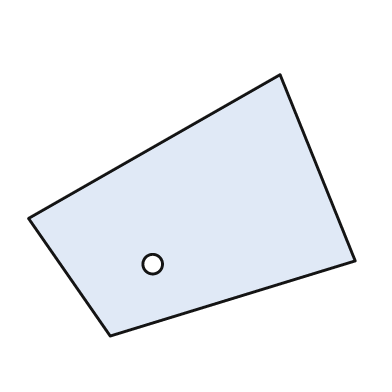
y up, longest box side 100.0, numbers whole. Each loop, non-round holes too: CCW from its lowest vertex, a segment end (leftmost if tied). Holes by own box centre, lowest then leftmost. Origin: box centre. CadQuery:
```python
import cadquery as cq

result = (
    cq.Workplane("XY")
    .moveTo(-25.0, -40.0)
    .lineTo(50.0, -17.0)
    .lineTo(27.0, 40.0)
    .lineTo(-50.0, -4.0)
    .close()
    .moveTo(-12.0, -18.0)
    .circle(3.0)
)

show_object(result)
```